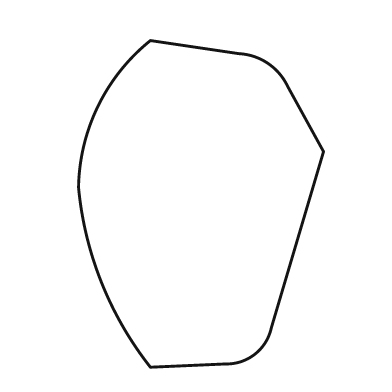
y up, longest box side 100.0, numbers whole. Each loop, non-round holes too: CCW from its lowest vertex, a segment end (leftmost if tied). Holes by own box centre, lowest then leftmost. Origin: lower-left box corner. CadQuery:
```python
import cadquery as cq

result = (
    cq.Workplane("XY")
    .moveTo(22.0, 0.0)
    .lineTo(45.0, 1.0)
    .threePointArc((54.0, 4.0), (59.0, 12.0))
    .lineTo(75.0, 66.0)
    .lineTo(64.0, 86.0)
    .threePointArc((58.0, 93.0), (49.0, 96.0))
    .lineTo(22.0, 100.0)
    .threePointArc((6.0, 80.0), (0.0, 55.0))
    .threePointArc((7.0, 26.0), (22.0, 0.0))
    .close()
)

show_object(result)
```